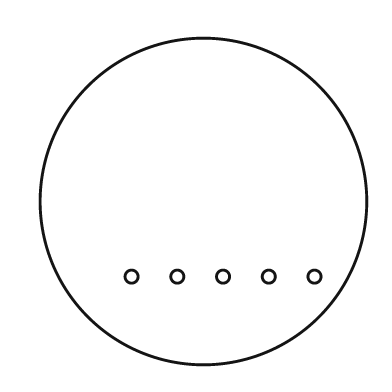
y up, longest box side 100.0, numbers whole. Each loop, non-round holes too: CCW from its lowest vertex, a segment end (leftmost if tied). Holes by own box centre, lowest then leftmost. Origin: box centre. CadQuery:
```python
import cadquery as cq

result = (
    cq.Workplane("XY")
    .moveTo(0.0, 0.0)
    .circle(50.0)
    .moveTo(-22.0, -23.0)
    .circle(2.0)
    .moveTo(-8.0, -23.0)
    .circle(2.0)
    .moveTo(6.0, -23.0)
    .circle(2.0)
    .moveTo(20.0, -23.0)
    .circle(2.0)
    .moveTo(34.0, -23.0)
    .circle(2.0)
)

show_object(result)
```